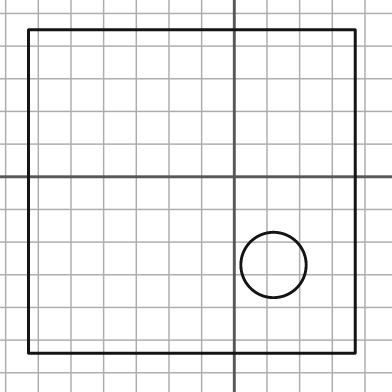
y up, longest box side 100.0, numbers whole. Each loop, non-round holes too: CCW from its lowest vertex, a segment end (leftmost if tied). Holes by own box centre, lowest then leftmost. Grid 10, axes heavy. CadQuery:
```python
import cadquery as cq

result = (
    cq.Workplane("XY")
    .moveTo(-63.0, -54.0)
    .lineTo(37.0, -54.0)
    .lineTo(37.0, 45.0)
    .lineTo(-63.0, 45.0)
    .close()
    .moveTo(12.0, -27.0)
    .circle(10.0)
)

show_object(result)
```